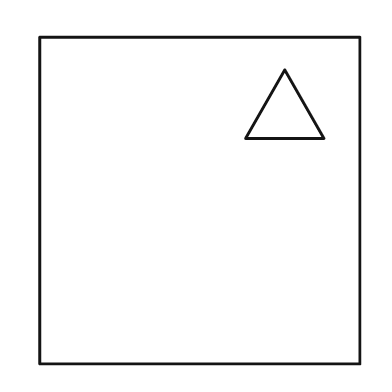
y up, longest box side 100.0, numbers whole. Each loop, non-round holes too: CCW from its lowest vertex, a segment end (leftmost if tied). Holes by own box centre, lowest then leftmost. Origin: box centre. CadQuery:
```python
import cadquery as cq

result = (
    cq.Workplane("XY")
    .moveTo(-49.0, -50.0)
    .lineTo(49.0, -50.0)
    .lineTo(49.0, 50.0)
    .lineTo(-49.0, 50.0)
    .close()
    .moveTo(14.0, 19.0)
    .lineTo(38.0, 19.0)
    .lineTo(26.0, 40.0)
    .close()
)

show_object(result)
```